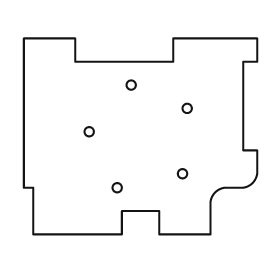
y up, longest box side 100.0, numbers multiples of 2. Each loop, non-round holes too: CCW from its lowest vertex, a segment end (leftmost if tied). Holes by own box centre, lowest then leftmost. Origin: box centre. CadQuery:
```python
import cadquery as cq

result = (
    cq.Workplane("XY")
    .moveTo(-46.0, -42.0)
    .lineTo(-8.0, -42.0)
    .lineTo(-8.0, -32.0)
    .lineTo(8.0, -32.0)
    .lineTo(8.0, -42.0)
    .lineTo(30.0, -42.0)
    .lineTo(30.0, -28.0)
    .threePointArc((32.0, -24.0), (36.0, -22.0))
    .lineTo(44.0, -22.0)
    .threePointArc((48.0, -20.0), (50.0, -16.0))
    .lineTo(50.0, -6.0)
    .lineTo(44.0, -6.0)
    .lineTo(44.0, 32.0)
    .lineTo(50.0, 32.0)
    .lineTo(50.0, 42.0)
    .lineTo(14.0, 42.0)
    .lineTo(14.0, 32.0)
    .lineTo(-28.0, 32.0)
    .lineTo(-28.0, 42.0)
    .lineTo(-50.0, 42.0)
    .lineTo(-50.0, -22.0)
    .lineTo(-46.0, -22.0)
    .close()
    .moveTo(-10.0, -22.0)
    .circle(2.0)
    .moveTo(18.0, -16.0)
    .circle(2.0)
    .moveTo(-22.0, 2.0)
    .circle(2.0)
    .moveTo(20.0, 12.0)
    .circle(2.0)
    .moveTo(-4.0, 22.0)
    .circle(2.0)
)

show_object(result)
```